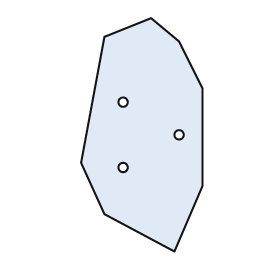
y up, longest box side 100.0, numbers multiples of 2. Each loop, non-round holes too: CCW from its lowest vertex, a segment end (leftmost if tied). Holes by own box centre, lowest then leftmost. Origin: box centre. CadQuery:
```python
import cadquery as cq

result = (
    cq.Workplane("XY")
    .moveTo(14.0, -50.0)
    .lineTo(26.0, -22.0)
    .lineTo(26.0, 20.0)
    .lineTo(16.0, 40.0)
    .lineTo(4.0, 50.0)
    .lineTo(-16.0, 42.0)
    .lineTo(-26.0, -12.0)
    .lineTo(-16.0, -34.0)
    .close()
    .moveTo(-8.0, -14.0)
    .circle(2.0)
    .moveTo(16.0, 0.0)
    .circle(2.0)
    .moveTo(-8.0, 14.0)
    .circle(2.0)
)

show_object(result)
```